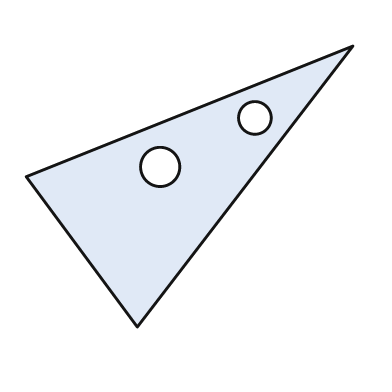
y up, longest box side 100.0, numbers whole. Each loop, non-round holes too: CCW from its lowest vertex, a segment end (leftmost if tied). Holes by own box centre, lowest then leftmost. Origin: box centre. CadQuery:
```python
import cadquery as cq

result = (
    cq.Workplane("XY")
    .moveTo(-16.0, -43.0)
    .lineTo(50.0, 43.0)
    .lineTo(-50.0, 3.0)
    .close()
    .moveTo(-9.0, 6.0)
    .circle(6.0)
    .moveTo(20.0, 21.0)
    .circle(5.0)
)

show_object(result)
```